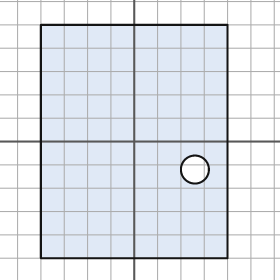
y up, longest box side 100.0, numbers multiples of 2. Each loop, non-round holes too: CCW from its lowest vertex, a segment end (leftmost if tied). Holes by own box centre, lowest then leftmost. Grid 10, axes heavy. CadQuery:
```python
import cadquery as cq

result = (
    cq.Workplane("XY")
    .moveTo(-40.0, -50.0)
    .lineTo(40.0, -50.0)
    .lineTo(40.0, 50.0)
    .lineTo(-40.0, 50.0)
    .close()
    .moveTo(26.0, -12.0)
    .circle(6.0)
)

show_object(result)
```